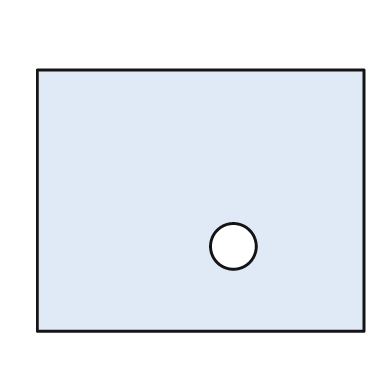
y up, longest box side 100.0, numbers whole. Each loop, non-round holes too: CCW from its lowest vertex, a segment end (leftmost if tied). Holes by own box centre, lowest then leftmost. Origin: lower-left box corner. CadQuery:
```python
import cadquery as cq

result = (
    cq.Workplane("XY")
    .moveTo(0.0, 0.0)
    .lineTo(100.0, 0.0)
    .lineTo(100.0, 80.0)
    .lineTo(0.0, 80.0)
    .close()
    .moveTo(60.0, 26.0)
    .circle(7.0)
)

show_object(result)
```